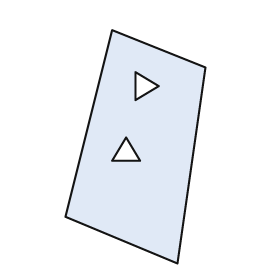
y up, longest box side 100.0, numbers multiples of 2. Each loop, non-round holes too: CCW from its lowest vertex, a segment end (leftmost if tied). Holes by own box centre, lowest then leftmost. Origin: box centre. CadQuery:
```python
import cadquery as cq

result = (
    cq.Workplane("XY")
    .moveTo(18.0, -50.0)
    .lineTo(30.0, 34.0)
    .lineTo(-10.0, 50.0)
    .lineTo(-30.0, -30.0)
    .close()
    .moveTo(-10.0, -6.0)
    .lineTo(2.0, -6.0)
    .lineTo(-4.0, 4.0)
    .close()
    .moveTo(0.0, 20.0)
    .lineTo(10.0, 26.0)
    .lineTo(0.0, 32.0)
    .close()
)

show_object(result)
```